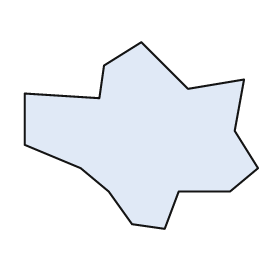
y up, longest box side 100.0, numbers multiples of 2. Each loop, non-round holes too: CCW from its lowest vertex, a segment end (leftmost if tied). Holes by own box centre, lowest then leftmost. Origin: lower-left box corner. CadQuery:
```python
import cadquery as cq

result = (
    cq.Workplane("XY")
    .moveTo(60.0, 0.0)
    .lineTo(66.0, 16.0)
    .lineTo(88.0, 16.0)
    .lineTo(100.0, 26.0)
    .lineTo(90.0, 42.0)
    .lineTo(94.0, 64.0)
    .lineTo(70.0, 60.0)
    .lineTo(50.0, 80.0)
    .lineTo(34.0, 70.0)
    .lineTo(32.0, 56.0)
    .lineTo(0.0, 58.0)
    .lineTo(0.0, 36.0)
    .lineTo(24.0, 26.0)
    .lineTo(36.0, 16.0)
    .lineTo(46.0, 2.0)
    .close()
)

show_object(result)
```